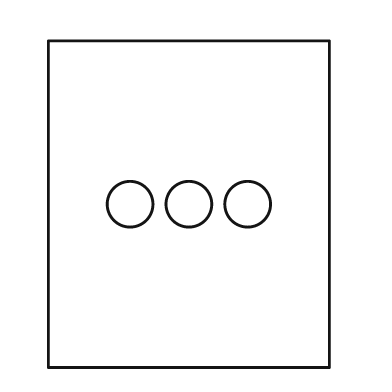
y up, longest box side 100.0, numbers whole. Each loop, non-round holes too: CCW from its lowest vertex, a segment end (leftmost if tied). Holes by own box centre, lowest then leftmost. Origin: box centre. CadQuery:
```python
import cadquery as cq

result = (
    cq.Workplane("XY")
    .moveTo(-43.0, -50.0)
    .lineTo(43.0, -50.0)
    .lineTo(43.0, 50.0)
    .lineTo(-43.0, 50.0)
    .close()
    .moveTo(-18.0, 0.0)
    .circle(7.0)
    .moveTo(0.0, 0.0)
    .circle(7.0)
    .moveTo(18.0, 0.0)
    .circle(7.0)
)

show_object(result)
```